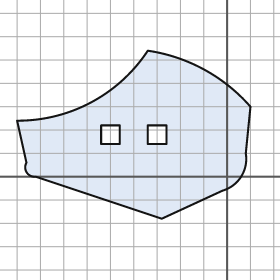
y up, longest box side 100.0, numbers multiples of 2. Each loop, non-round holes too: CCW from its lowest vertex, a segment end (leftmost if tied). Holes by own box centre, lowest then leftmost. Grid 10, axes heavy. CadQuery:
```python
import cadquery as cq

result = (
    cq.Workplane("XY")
    .moveTo(-28.0, -18.0)
    .lineTo(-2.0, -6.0)
    .threePointArc((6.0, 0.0), (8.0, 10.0))
    .lineTo(10.0, 30.0)
    .threePointArc((-10.0, 46.0), (-34.0, 54.0))
    .threePointArc((-58.0, 32.0), (-90.0, 24.0))
    .lineTo(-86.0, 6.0)
    .threePointArc((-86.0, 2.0), (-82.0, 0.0))
    .close()
    .moveTo(-54.0, 14.0)
    .lineTo(-46.0, 14.0)
    .lineTo(-46.0, 22.0)
    .lineTo(-54.0, 22.0)
    .close()
    .moveTo(-34.0, 14.0)
    .lineTo(-26.0, 14.0)
    .lineTo(-26.0, 22.0)
    .lineTo(-34.0, 22.0)
    .close()
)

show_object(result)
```